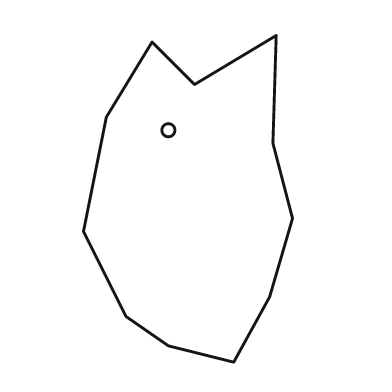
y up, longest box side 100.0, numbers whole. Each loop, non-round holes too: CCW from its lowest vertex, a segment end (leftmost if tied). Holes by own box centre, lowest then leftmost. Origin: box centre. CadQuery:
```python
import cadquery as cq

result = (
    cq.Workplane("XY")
    .moveTo(14.0, -50.0)
    .lineTo(25.0, -30.0)
    .lineTo(32.0, -6.0)
    .lineTo(26.0, 17.0)
    .lineTo(27.0, 50.0)
    .lineTo(2.0, 35.0)
    .lineTo(-11.0, 48.0)
    .lineTo(-25.0, 25.0)
    .lineTo(-32.0, -10.0)
    .lineTo(-19.0, -36.0)
    .lineTo(-6.0, -45.0)
    .close()
    .moveTo(-6.0, 21.0)
    .circle(2.0)
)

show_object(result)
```